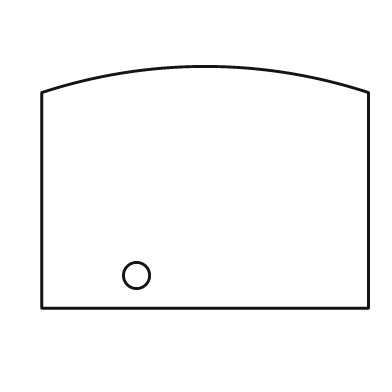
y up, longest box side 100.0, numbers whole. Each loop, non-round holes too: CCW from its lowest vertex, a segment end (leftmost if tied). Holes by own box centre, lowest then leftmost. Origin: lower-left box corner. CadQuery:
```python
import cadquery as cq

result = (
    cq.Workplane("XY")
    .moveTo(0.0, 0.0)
    .lineTo(100.0, 0.0)
    .lineTo(100.0, 66.0)
    .threePointArc((50.0, 74.0), (0.0, 66.0))
    .close()
    .moveTo(29.0, 10.0)
    .circle(4.0)
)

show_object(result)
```